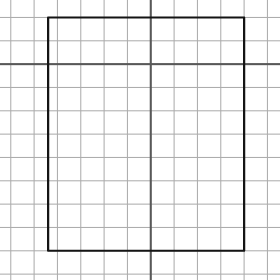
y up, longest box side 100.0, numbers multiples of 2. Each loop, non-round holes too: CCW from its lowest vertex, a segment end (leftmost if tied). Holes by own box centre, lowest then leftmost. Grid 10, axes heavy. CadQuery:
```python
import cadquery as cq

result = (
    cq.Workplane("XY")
    .moveTo(-44.0, -80.0)
    .lineTo(40.0, -80.0)
    .lineTo(40.0, 20.0)
    .lineTo(-44.0, 20.0)
    .close()
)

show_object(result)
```